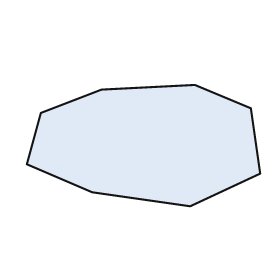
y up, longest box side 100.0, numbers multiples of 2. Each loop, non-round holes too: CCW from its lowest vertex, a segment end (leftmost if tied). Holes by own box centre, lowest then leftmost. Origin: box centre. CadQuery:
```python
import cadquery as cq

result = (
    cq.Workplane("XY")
    .moveTo(20.0, -26.0)
    .lineTo(50.0, -12.0)
    .lineTo(46.0, 16.0)
    .lineTo(22.0, 26.0)
    .lineTo(-18.0, 24.0)
    .lineTo(-44.0, 14.0)
    .lineTo(-50.0, -8.0)
    .lineTo(-22.0, -20.0)
    .close()
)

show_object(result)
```